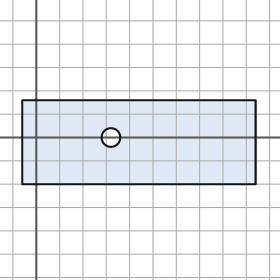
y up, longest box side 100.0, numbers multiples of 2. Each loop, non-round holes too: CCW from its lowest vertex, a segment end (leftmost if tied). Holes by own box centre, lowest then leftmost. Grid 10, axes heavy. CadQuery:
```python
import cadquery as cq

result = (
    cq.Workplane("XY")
    .moveTo(-6.0, -20.0)
    .lineTo(94.0, -20.0)
    .lineTo(94.0, 16.0)
    .lineTo(-6.0, 16.0)
    .close()
    .moveTo(32.0, 0.0)
    .circle(4.0)
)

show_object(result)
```